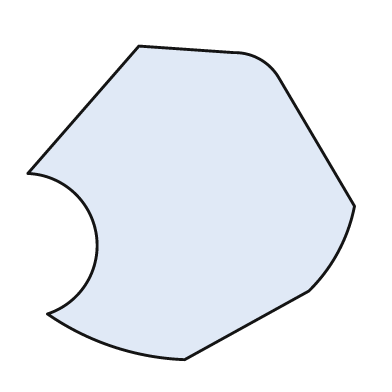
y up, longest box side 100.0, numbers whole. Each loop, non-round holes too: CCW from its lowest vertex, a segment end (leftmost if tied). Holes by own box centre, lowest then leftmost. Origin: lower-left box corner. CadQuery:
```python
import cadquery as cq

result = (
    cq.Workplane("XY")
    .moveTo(48.0, 0.0)
    .lineTo(86.0, 21.0)
    .threePointArc((95.0, 33.0), (100.0, 47.0))
    .lineTo(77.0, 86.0)
    .threePointArc((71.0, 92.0), (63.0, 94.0))
    .lineTo(34.0, 96.0)
    .lineTo(0.0, 57.0)
    .threePointArc((21.0, 38.0), (6.0, 14.0))
    .threePointArc((26.0, 4.0), (48.0, 0.0))
    .close()
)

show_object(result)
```